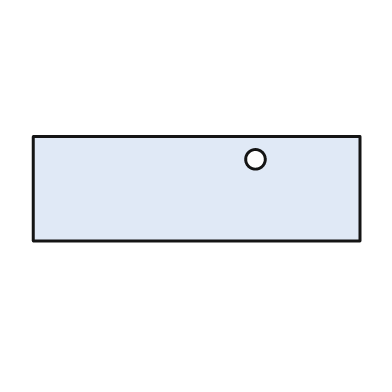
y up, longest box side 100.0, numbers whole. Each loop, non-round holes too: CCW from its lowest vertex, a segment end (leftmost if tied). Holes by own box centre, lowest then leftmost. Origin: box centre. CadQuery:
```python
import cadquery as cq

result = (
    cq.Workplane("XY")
    .moveTo(-50.0, -16.0)
    .lineTo(50.0, -16.0)
    .lineTo(50.0, 16.0)
    .lineTo(-50.0, 16.0)
    .close()
    .moveTo(18.0, 9.0)
    .circle(3.0)
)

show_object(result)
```